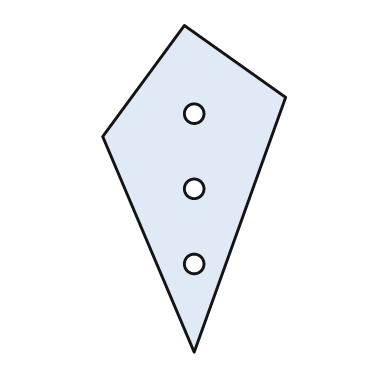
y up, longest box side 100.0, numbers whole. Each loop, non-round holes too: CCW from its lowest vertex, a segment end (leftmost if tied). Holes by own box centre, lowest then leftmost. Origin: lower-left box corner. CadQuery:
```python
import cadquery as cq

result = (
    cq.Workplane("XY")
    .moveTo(28.0, 0.0)
    .lineTo(56.0, 78.0)
    .lineTo(25.0, 100.0)
    .lineTo(0.0, 66.0)
    .close()
    .moveTo(28.0, 27.0)
    .circle(3.0)
    .moveTo(28.0, 50.0)
    .circle(3.0)
    .moveTo(28.0, 73.0)
    .circle(3.0)
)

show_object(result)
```